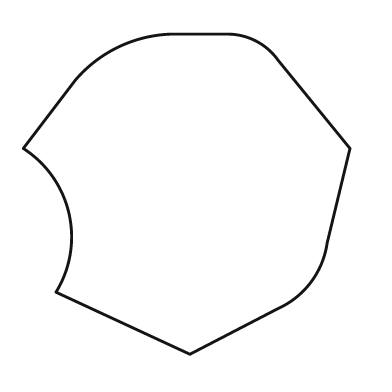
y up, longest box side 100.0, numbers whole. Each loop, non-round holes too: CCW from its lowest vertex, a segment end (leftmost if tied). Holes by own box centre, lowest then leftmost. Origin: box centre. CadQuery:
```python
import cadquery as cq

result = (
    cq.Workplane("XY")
    .moveTo(1.0, -49.0)
    .lineTo(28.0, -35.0)
    .threePointArc((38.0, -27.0), (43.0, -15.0))
    .lineTo(50.0, 14.0)
    .lineTo(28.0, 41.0)
    .threePointArc((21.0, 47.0), (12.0, 49.0))
    .lineTo(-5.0, 49.0)
    .threePointArc((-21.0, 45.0), (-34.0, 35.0))
    .lineTo(-50.0, 14.0)
    .threePointArc((-36.0, -6.0), (-40.0, -30.0))
    .close()
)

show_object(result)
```